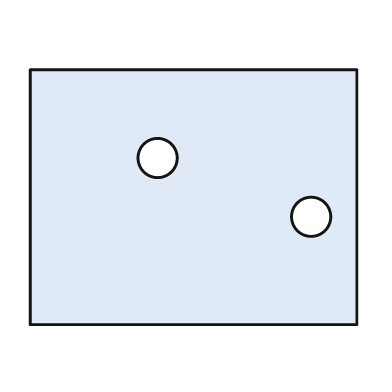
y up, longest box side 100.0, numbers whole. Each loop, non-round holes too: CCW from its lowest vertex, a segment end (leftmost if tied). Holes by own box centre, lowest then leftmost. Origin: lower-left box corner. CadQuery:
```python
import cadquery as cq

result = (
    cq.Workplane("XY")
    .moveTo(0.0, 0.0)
    .lineTo(100.0, 0.0)
    .lineTo(100.0, 78.0)
    .lineTo(0.0, 78.0)
    .close()
    .moveTo(86.0, 33.0)
    .circle(6.0)
    .moveTo(39.0, 51.0)
    .circle(6.0)
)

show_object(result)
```